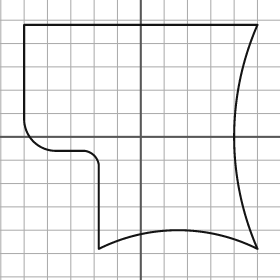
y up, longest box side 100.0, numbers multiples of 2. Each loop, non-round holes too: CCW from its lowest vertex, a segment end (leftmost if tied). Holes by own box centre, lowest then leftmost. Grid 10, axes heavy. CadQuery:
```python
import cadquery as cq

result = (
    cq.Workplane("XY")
    .moveTo(-18.0, -48.0)
    .threePointArc((16.0, -40.0), (50.0, -48.0))
    .threePointArc((40.0, 0.0), (50.0, 48.0))
    .lineTo(-50.0, 48.0)
    .lineTo(-50.0, 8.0)
    .threePointArc((-46.0, -2.0), (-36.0, -6.0))
    .lineTo(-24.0, -6.0)
    .threePointArc((-20.0, -8.0), (-18.0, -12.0))
    .close()
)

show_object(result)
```